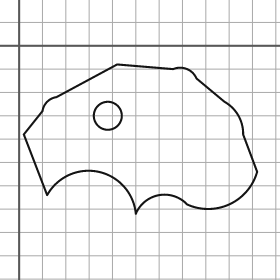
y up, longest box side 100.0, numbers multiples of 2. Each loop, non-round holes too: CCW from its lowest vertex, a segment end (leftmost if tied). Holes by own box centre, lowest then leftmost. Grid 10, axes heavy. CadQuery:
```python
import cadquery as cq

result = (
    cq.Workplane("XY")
    .moveTo(50.0, -72.0)
    .threePointArc((60.0, -64.0), (72.0, -68.0))
    .threePointArc((90.0, -68.0), (102.0, -54.0))
    .lineTo(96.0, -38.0)
    .threePointArc((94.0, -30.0), (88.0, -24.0))
    .lineTo(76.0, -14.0)
    .threePointArc((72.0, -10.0), (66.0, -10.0))
    .lineTo(42.0, -8.0)
    .lineTo(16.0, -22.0)
    .threePointArc((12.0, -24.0), (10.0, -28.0))
    .lineTo(2.0, -38.0)
    .lineTo(12.0, -64.0)
    .threePointArc((34.0, -54.0), (50.0, -72.0))
    .close()
    .moveTo(38.0, -30.0)
    .circle(6.0)
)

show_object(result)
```